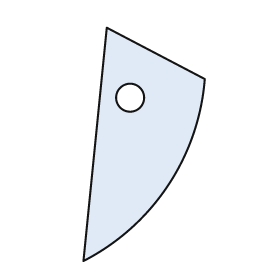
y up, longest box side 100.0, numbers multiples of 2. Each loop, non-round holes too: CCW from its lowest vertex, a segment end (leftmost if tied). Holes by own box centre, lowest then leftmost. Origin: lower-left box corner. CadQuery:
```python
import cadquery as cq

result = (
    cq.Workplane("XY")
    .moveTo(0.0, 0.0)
    .threePointArc((36.0, 32.0), (52.0, 78.0))
    .lineTo(10.0, 100.0)
    .close()
    .moveTo(20.0, 70.0)
    .circle(6.0)
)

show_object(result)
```